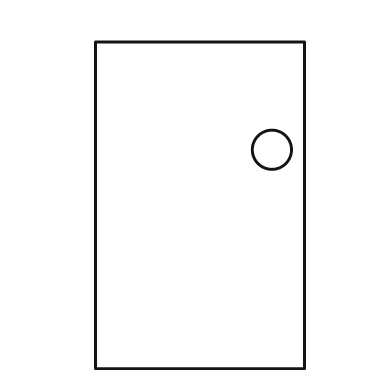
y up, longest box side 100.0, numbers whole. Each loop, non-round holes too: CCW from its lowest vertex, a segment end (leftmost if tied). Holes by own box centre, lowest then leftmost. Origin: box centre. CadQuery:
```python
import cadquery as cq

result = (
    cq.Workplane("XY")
    .moveTo(-32.0, -50.0)
    .lineTo(32.0, -50.0)
    .lineTo(32.0, 50.0)
    .lineTo(-32.0, 50.0)
    .close()
    .moveTo(22.0, 17.0)
    .circle(6.0)
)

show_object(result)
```